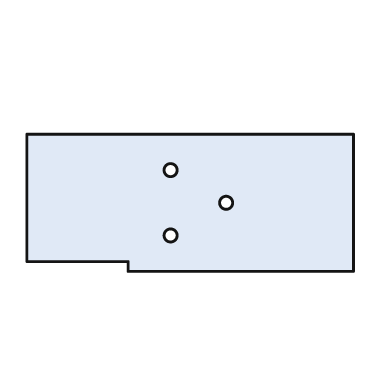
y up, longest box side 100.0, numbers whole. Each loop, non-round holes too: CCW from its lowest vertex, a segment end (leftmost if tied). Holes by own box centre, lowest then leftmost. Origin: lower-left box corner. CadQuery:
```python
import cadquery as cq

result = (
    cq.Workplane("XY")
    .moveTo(31.0, 0.0)
    .lineTo(100.0, 0.0)
    .lineTo(100.0, 42.0)
    .lineTo(0.0, 42.0)
    .lineTo(0.0, 3.0)
    .lineTo(31.0, 3.0)
    .close()
    .moveTo(44.0, 11.0)
    .circle(2.0)
    .moveTo(61.0, 21.0)
    .circle(2.0)
    .moveTo(44.0, 31.0)
    .circle(2.0)
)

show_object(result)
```